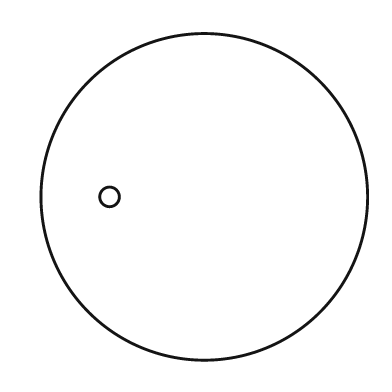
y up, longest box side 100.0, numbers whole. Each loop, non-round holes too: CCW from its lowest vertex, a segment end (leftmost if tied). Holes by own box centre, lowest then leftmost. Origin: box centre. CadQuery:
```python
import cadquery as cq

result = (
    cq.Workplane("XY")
    .moveTo(0.0, 0.0)
    .circle(50.0)
    .moveTo(-29.0, 0.0)
    .circle(3.0)
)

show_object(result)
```